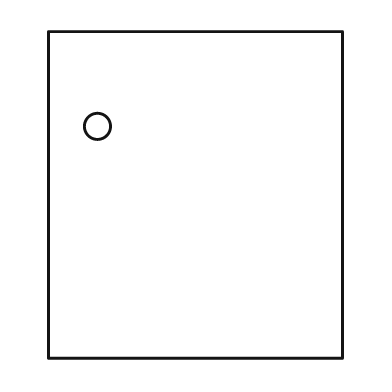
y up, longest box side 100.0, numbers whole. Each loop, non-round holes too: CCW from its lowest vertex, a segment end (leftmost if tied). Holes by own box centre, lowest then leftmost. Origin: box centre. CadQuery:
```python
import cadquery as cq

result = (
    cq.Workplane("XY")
    .moveTo(-45.0, -50.0)
    .lineTo(45.0, -50.0)
    .lineTo(45.0, 50.0)
    .lineTo(-45.0, 50.0)
    .close()
    .moveTo(-30.0, 21.0)
    .circle(4.0)
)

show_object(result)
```